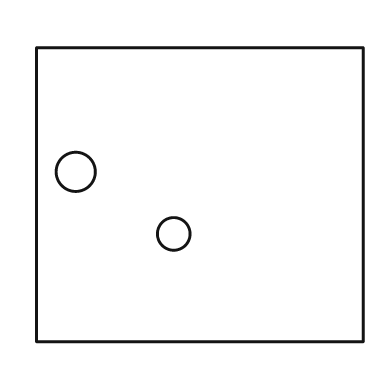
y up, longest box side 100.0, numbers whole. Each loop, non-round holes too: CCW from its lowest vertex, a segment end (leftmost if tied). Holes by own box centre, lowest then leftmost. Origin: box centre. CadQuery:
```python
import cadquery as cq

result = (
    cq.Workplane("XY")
    .moveTo(-50.0, -45.0)
    .lineTo(50.0, -45.0)
    .lineTo(50.0, 45.0)
    .lineTo(-50.0, 45.0)
    .close()
    .moveTo(-8.0, -12.0)
    .circle(5.0)
    .moveTo(-38.0, 7.0)
    .circle(6.0)
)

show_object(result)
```